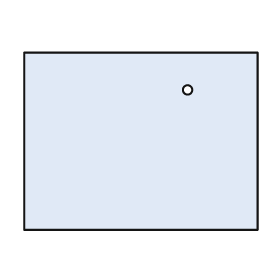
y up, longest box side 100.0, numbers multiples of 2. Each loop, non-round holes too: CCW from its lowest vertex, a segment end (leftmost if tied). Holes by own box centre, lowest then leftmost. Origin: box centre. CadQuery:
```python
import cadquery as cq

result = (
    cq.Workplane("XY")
    .moveTo(-50.0, -38.0)
    .lineTo(50.0, -38.0)
    .lineTo(50.0, 38.0)
    .lineTo(-50.0, 38.0)
    .close()
    .moveTo(20.0, 22.0)
    .circle(2.0)
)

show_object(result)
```